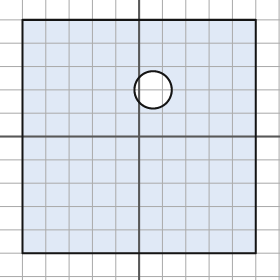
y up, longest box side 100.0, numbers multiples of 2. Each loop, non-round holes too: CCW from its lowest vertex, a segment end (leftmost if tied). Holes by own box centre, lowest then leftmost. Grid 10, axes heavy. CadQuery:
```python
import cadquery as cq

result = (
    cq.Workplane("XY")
    .moveTo(-50.0, -50.0)
    .lineTo(50.0, -50.0)
    .lineTo(50.0, 50.0)
    .lineTo(-50.0, 50.0)
    .close()
    .moveTo(6.0, 20.0)
    .circle(8.0)
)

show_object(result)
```